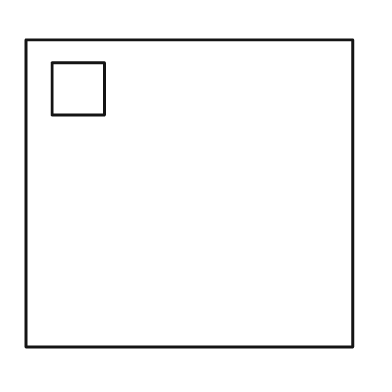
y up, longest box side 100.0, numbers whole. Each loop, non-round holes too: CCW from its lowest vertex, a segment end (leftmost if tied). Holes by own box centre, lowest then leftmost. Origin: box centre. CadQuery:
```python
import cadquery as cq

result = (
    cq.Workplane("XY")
    .moveTo(-50.0, -47.0)
    .lineTo(50.0, -47.0)
    .lineTo(50.0, 47.0)
    .lineTo(-50.0, 47.0)
    .close()
    .moveTo(-42.0, 24.0)
    .lineTo(-26.0, 24.0)
    .lineTo(-26.0, 40.0)
    .lineTo(-42.0, 40.0)
    .close()
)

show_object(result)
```